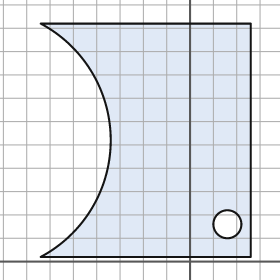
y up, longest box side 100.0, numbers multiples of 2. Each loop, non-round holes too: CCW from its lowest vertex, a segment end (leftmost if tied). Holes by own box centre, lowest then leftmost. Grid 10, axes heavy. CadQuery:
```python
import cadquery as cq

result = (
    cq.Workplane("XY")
    .moveTo(-64.0, 2.0)
    .lineTo(26.0, 2.0)
    .lineTo(26.0, 102.0)
    .lineTo(-64.0, 102.0)
    .threePointArc((-34.0, 52.0), (-64.0, 2.0))
    .close()
    .moveTo(16.0, 16.0)
    .circle(6.0)
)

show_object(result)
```